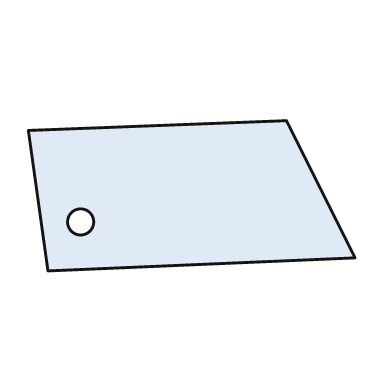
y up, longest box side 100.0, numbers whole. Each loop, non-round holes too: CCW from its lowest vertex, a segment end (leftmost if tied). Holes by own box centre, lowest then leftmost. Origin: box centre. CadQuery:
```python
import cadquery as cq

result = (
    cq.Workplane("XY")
    .moveTo(-44.0, -23.0)
    .lineTo(50.0, -19.0)
    .lineTo(29.0, 23.0)
    .lineTo(-50.0, 20.0)
    .close()
    .moveTo(-34.0, -8.0)
    .circle(4.0)
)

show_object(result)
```